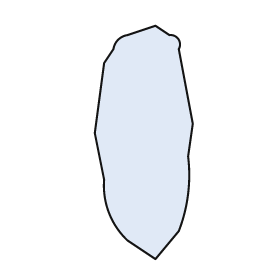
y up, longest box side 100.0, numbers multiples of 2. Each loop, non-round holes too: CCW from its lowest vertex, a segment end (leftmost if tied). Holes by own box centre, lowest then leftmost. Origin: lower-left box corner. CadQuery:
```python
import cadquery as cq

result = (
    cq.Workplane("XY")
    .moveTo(26.0, 0.0)
    .lineTo(36.0, 12.0)
    .threePointArc((40.0, 28.0), (40.0, 44.0))
    .lineTo(42.0, 58.0)
    .lineTo(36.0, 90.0)
    .threePointArc((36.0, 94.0), (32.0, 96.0))
    .lineTo(26.0, 100.0)
    .lineTo(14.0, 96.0)
    .threePointArc((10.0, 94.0), (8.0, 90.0))
    .lineTo(4.0, 84.0)
    .lineTo(0.0, 54.0)
    .lineTo(4.0, 34.0)
    .threePointArc((6.0, 20.0), (14.0, 8.0))
    .close()
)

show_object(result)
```